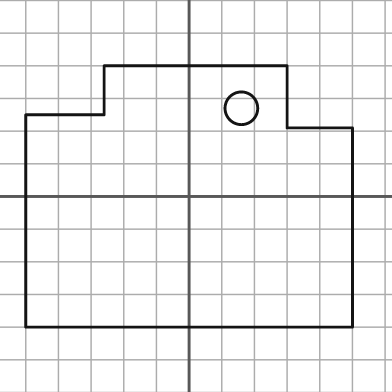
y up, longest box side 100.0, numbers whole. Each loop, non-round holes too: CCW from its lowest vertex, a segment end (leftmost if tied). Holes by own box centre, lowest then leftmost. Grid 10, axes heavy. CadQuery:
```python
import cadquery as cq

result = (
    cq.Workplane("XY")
    .moveTo(-50.0, -40.0)
    .lineTo(50.0, -40.0)
    .lineTo(50.0, 21.0)
    .lineTo(30.0, 21.0)
    .lineTo(30.0, 40.0)
    .lineTo(-26.0, 40.0)
    .lineTo(-26.0, 25.0)
    .lineTo(-50.0, 25.0)
    .close()
    .moveTo(16.0, 27.0)
    .circle(5.0)
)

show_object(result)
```